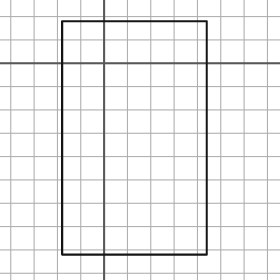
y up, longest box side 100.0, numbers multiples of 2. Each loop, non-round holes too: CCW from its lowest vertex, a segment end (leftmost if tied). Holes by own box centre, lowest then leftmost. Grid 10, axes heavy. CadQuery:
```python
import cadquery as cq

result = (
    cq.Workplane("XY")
    .moveTo(-18.0, -82.0)
    .lineTo(44.0, -82.0)
    .lineTo(44.0, 18.0)
    .lineTo(-18.0, 18.0)
    .close()
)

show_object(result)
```